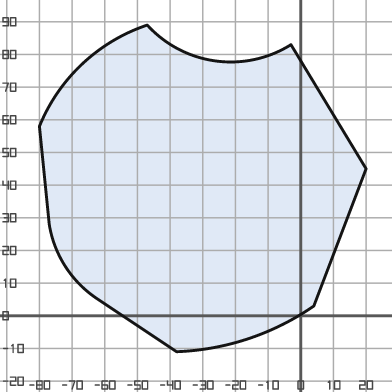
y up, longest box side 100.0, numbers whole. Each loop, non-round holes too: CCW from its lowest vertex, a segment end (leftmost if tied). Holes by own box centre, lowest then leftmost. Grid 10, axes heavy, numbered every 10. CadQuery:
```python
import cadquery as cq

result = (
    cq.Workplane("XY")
    .moveTo(-38.0, -11.0)
    .threePointArc((-16.0, -7.0), (4.0, 3.0))
    .lineTo(20.0, 45.0)
    .lineTo(-3.0, 83.0)
    .threePointArc((-26.0, 78.0), (-47.0, 89.0))
    .threePointArc((-67.0, 77.0), (-80.0, 58.0))
    .lineTo(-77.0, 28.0)
    .threePointArc((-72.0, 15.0), (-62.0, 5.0))
    .close()
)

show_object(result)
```